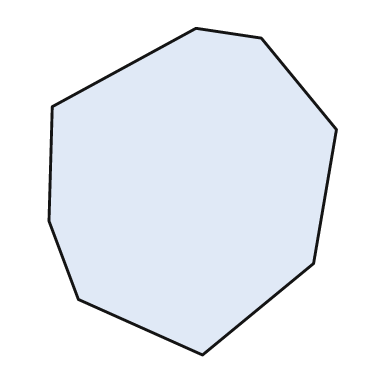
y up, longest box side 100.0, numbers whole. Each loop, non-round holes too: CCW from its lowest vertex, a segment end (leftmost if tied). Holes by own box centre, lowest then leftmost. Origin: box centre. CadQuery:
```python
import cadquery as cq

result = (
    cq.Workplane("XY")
    .moveTo(3.0, -50.0)
    .lineTo(37.0, -22.0)
    .lineTo(44.0, 19.0)
    .lineTo(21.0, 47.0)
    .lineTo(1.0, 50.0)
    .lineTo(-43.0, 26.0)
    .lineTo(-44.0, -9.0)
    .lineTo(-35.0, -33.0)
    .close()
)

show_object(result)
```